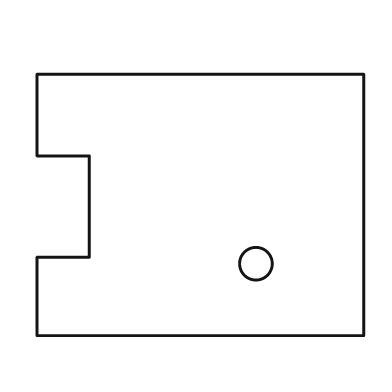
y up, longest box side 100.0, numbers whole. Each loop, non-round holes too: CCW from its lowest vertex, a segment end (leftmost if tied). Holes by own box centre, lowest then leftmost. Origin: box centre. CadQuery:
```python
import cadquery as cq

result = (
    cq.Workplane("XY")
    .moveTo(-50.0, -40.0)
    .lineTo(50.0, -40.0)
    .lineTo(50.0, 40.0)
    .lineTo(-50.0, 40.0)
    .lineTo(-50.0, 15.0)
    .lineTo(-34.0, 15.0)
    .lineTo(-34.0, -16.0)
    .lineTo(-50.0, -16.0)
    .close()
    .moveTo(17.0, -18.0)
    .circle(5.0)
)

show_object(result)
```